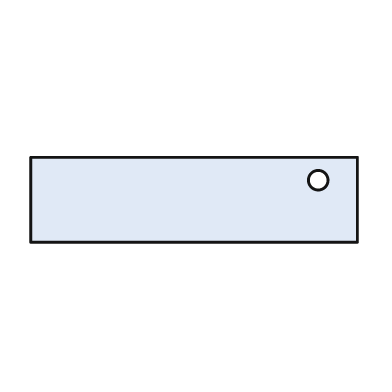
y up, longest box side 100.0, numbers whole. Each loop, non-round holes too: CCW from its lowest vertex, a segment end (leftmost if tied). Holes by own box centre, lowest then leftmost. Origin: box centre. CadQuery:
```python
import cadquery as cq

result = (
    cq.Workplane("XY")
    .moveTo(-50.0, -13.0)
    .lineTo(50.0, -13.0)
    .lineTo(50.0, 13.0)
    .lineTo(-50.0, 13.0)
    .close()
    .moveTo(38.0, 6.0)
    .circle(3.0)
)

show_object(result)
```